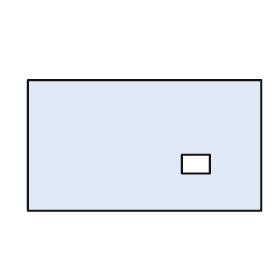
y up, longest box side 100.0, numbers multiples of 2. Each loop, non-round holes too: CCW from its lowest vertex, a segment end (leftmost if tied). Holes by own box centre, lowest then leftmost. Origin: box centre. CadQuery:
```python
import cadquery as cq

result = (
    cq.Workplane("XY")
    .moveTo(-50.0, -28.0)
    .lineTo(50.0, -28.0)
    .lineTo(50.0, 28.0)
    .lineTo(-50.0, 28.0)
    .close()
    .moveTo(16.0, -12.0)
    .lineTo(28.0, -12.0)
    .lineTo(28.0, -4.0)
    .lineTo(16.0, -4.0)
    .close()
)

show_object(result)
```